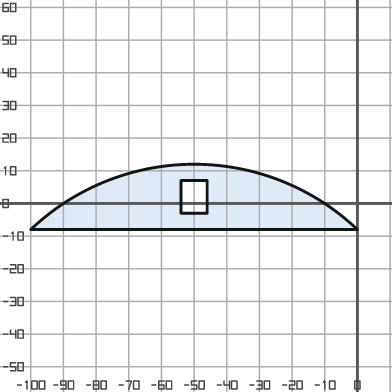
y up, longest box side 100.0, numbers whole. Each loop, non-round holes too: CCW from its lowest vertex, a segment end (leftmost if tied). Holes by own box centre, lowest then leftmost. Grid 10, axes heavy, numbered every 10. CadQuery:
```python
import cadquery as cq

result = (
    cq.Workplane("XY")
    .moveTo(-100.0, -8.0)
    .lineTo(0.0, -8.0)
    .threePointArc((-50.0, 12.0), (-100.0, -8.0))
    .close()
    .moveTo(-54.0, -3.0)
    .lineTo(-46.0, -3.0)
    .lineTo(-46.0, 7.0)
    .lineTo(-54.0, 7.0)
    .close()
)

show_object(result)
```